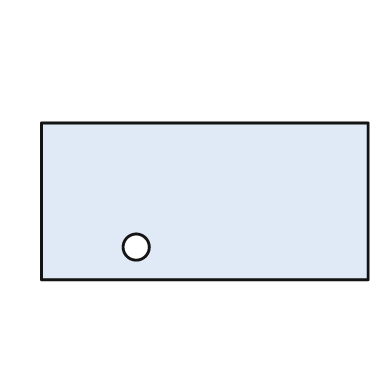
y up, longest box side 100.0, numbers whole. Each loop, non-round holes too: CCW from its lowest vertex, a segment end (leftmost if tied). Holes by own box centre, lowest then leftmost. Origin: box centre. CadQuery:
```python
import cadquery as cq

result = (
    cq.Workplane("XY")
    .moveTo(-50.0, -24.0)
    .lineTo(50.0, -24.0)
    .lineTo(50.0, 24.0)
    .lineTo(-50.0, 24.0)
    .close()
    .moveTo(-21.0, -14.0)
    .circle(4.0)
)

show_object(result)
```